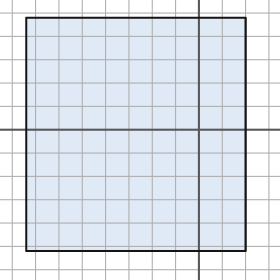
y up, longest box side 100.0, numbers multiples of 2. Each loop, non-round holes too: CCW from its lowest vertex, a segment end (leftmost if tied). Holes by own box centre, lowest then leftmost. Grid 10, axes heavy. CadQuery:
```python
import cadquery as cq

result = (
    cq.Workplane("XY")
    .moveTo(-74.0, -52.0)
    .lineTo(20.0, -52.0)
    .lineTo(20.0, 48.0)
    .lineTo(-74.0, 48.0)
    .close()
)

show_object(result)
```